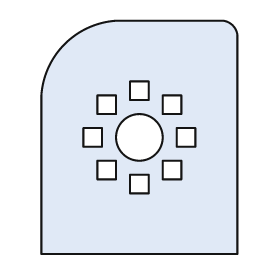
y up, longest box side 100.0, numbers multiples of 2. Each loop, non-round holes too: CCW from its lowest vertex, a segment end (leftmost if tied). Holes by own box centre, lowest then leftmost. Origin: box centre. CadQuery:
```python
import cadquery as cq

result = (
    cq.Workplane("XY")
    .moveTo(-42.0, -50.0)
    .lineTo(42.0, -50.0)
    .lineTo(42.0, 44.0)
    .threePointArc((40.0, 48.0), (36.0, 50.0))
    .lineTo(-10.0, 50.0)
    .threePointArc((-32.0, 40.0), (-42.0, 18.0))
    .close()
    .moveTo(-4.0, -24.0)
    .lineTo(4.0, -24.0)
    .lineTo(4.0, -16.0)
    .lineTo(-4.0, -16.0)
    .close()
    .moveTo(-18.0, -18.0)
    .lineTo(-10.0, -18.0)
    .lineTo(-10.0, -10.0)
    .lineTo(-18.0, -10.0)
    .close()
    .moveTo(10.0, -18.0)
    .lineTo(18.0, -18.0)
    .lineTo(18.0, -10.0)
    .lineTo(10.0, -10.0)
    .close()
    .moveTo(-24.0, -4.0)
    .lineTo(-16.0, -4.0)
    .lineTo(-16.0, 4.0)
    .lineTo(-24.0, 4.0)
    .close()
    .moveTo(0.0, 0.0)
    .circle(10.0)
    .moveTo(16.0, -4.0)
    .lineTo(24.0, -4.0)
    .lineTo(24.0, 4.0)
    .lineTo(16.0, 4.0)
    .close()
    .moveTo(-18.0, 10.0)
    .lineTo(-10.0, 10.0)
    .lineTo(-10.0, 18.0)
    .lineTo(-18.0, 18.0)
    .close()
    .moveTo(10.0, 10.0)
    .lineTo(18.0, 10.0)
    .lineTo(18.0, 18.0)
    .lineTo(10.0, 18.0)
    .close()
    .moveTo(-4.0, 16.0)
    .lineTo(4.0, 16.0)
    .lineTo(4.0, 24.0)
    .lineTo(-4.0, 24.0)
    .close()
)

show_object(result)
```